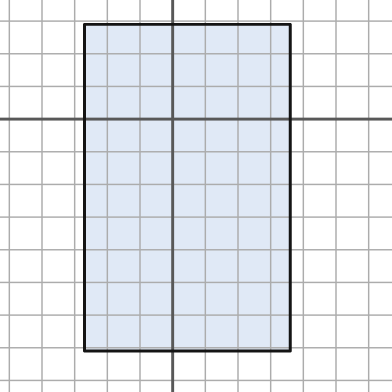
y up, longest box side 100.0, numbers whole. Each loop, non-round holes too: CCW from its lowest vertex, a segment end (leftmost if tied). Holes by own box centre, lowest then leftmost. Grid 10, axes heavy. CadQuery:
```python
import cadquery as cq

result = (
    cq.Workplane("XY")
    .moveTo(-27.0, -71.0)
    .lineTo(36.0, -71.0)
    .lineTo(36.0, 29.0)
    .lineTo(-27.0, 29.0)
    .close()
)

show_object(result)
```